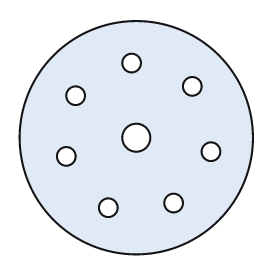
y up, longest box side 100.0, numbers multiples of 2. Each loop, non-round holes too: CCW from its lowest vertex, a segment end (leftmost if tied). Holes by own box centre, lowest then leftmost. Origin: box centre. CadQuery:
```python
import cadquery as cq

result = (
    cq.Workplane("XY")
    .moveTo(0.0, 0.0)
    .circle(50.0)
    .moveTo(-12.0, -30.0)
    .circle(4.0)
    .moveTo(16.0, -28.0)
    .circle(4.0)
    .moveTo(-30.0, -8.0)
    .circle(4.0)
    .moveTo(32.0, -6.0)
    .circle(4.0)
    .moveTo(0.0, 0.0)
    .circle(6.0)
    .moveTo(-26.0, 18.0)
    .circle(4.0)
    .moveTo(24.0, 22.0)
    .circle(4.0)
    .moveTo(-2.0, 32.0)
    .circle(4.0)
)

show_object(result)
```